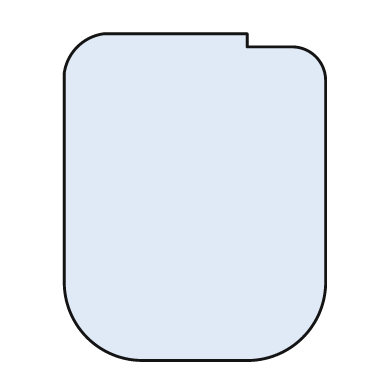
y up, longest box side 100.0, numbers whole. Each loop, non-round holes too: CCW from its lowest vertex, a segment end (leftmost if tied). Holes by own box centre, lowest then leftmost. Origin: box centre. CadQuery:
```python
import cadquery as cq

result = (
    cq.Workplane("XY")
    .moveTo(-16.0, -50.0)
    .lineTo(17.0, -50.0)
    .threePointArc((33.0, -43.0), (40.0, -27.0))
    .lineTo(40.0, 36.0)
    .threePointArc((37.0, 43.0), (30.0, 46.0))
    .lineTo(16.0, 46.0)
    .lineTo(16.0, 50.0)
    .lineTo(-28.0, 50.0)
    .threePointArc((-36.0, 46.0), (-40.0, 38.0))
    .lineTo(-40.0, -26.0)
    .threePointArc((-33.0, -43.0), (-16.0, -50.0))
    .close()
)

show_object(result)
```